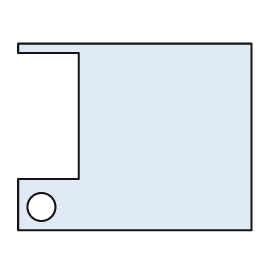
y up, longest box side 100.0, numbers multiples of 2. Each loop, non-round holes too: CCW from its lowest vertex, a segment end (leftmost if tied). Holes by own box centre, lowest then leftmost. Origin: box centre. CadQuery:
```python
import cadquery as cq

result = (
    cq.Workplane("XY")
    .moveTo(-50.0, -40.0)
    .lineTo(50.0, -40.0)
    .lineTo(50.0, 40.0)
    .lineTo(-50.0, 40.0)
    .lineTo(-50.0, 36.0)
    .lineTo(-24.0, 36.0)
    .lineTo(-24.0, -18.0)
    .lineTo(-50.0, -18.0)
    .close()
    .moveTo(-40.0, -30.0)
    .circle(6.0)
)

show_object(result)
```